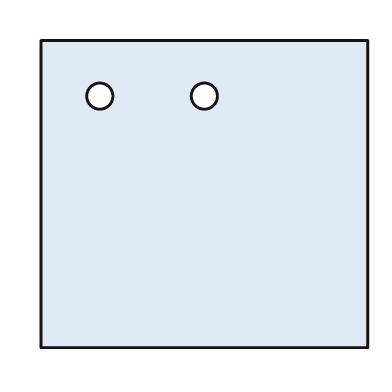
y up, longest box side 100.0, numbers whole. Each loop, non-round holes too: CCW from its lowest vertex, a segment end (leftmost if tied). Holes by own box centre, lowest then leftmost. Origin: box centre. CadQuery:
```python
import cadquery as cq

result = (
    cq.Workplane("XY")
    .moveTo(-50.0, -47.0)
    .lineTo(50.0, -47.0)
    .lineTo(50.0, 47.0)
    .lineTo(-50.0, 47.0)
    .close()
    .moveTo(-32.0, 30.0)
    .circle(4.0)
    .moveTo(0.0, 30.0)
    .circle(4.0)
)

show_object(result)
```